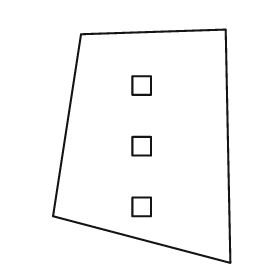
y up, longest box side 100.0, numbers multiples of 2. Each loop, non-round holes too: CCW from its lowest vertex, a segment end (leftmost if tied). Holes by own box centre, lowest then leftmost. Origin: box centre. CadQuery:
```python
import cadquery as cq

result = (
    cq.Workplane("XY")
    .moveTo(38.0, -50.0)
    .lineTo(36.0, 50.0)
    .lineTo(-26.0, 48.0)
    .lineTo(-38.0, -30.0)
    .close()
    .moveTo(-4.0, -30.0)
    .lineTo(4.0, -30.0)
    .lineTo(4.0, -22.0)
    .lineTo(-4.0, -22.0)
    .close()
    .moveTo(-4.0, -4.0)
    .lineTo(4.0, -4.0)
    .lineTo(4.0, 4.0)
    .lineTo(-4.0, 4.0)
    .close()
    .moveTo(-4.0, 22.0)
    .lineTo(4.0, 22.0)
    .lineTo(4.0, 30.0)
    .lineTo(-4.0, 30.0)
    .close()
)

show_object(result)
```